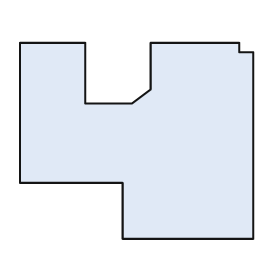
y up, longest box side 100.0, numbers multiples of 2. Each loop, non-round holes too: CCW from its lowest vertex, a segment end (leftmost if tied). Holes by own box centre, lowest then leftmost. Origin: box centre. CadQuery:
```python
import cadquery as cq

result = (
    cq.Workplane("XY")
    .moveTo(-6.0, -42.0)
    .lineTo(50.0, -42.0)
    .lineTo(50.0, 38.0)
    .lineTo(44.0, 38.0)
    .lineTo(44.0, 42.0)
    .lineTo(6.0, 42.0)
    .lineTo(6.0, 22.0)
    .lineTo(-2.0, 16.0)
    .lineTo(-22.0, 16.0)
    .lineTo(-22.0, 42.0)
    .lineTo(-50.0, 42.0)
    .lineTo(-50.0, -18.0)
    .lineTo(-6.0, -18.0)
    .close()
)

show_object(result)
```